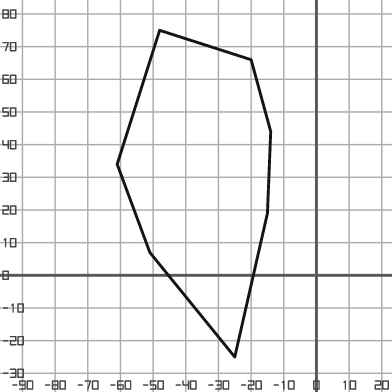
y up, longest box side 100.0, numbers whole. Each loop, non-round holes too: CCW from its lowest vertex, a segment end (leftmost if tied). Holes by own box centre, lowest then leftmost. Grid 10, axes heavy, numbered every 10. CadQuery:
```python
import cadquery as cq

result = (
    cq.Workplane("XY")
    .moveTo(-25.0, -25.0)
    .lineTo(-15.0, 19.0)
    .lineTo(-14.0, 44.0)
    .lineTo(-20.0, 66.0)
    .lineTo(-48.0, 75.0)
    .lineTo(-61.0, 34.0)
    .lineTo(-51.0, 7.0)
    .close()
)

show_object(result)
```